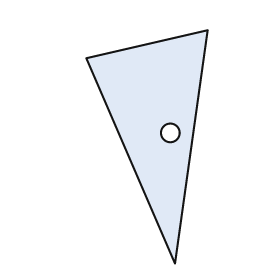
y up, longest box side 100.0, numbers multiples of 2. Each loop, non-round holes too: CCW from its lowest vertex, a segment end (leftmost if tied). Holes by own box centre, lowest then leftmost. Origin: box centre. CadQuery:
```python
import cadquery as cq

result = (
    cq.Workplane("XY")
    .moveTo(12.0, -50.0)
    .lineTo(26.0, 50.0)
    .lineTo(-26.0, 38.0)
    .close()
    .moveTo(10.0, 6.0)
    .circle(4.0)
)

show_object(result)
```